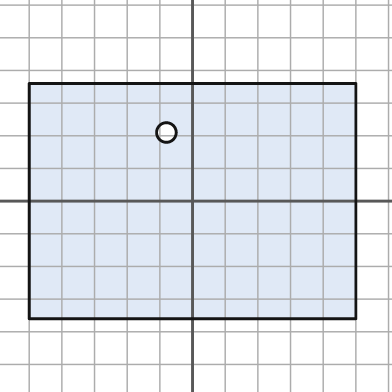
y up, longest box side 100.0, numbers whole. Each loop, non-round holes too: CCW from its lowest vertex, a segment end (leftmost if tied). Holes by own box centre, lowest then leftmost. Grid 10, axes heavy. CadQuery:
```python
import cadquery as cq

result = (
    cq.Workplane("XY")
    .moveTo(-50.0, -36.0)
    .lineTo(50.0, -36.0)
    .lineTo(50.0, 36.0)
    .lineTo(-50.0, 36.0)
    .close()
    .moveTo(-8.0, 21.0)
    .circle(3.0)
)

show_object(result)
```